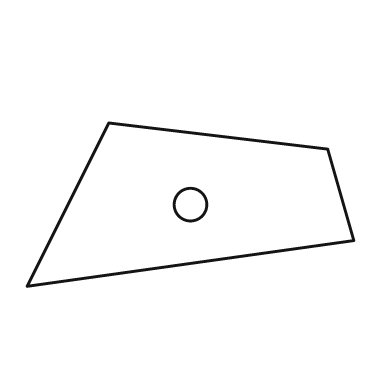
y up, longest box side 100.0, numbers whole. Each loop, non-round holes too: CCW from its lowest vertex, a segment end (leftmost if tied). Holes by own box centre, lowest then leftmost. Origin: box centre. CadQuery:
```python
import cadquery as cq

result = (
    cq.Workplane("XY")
    .moveTo(-50.0, -25.0)
    .lineTo(50.0, -11.0)
    .lineTo(42.0, 17.0)
    .lineTo(-25.0, 25.0)
    .close()
    .moveTo(0.0, 0.0)
    .circle(5.0)
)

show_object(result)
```